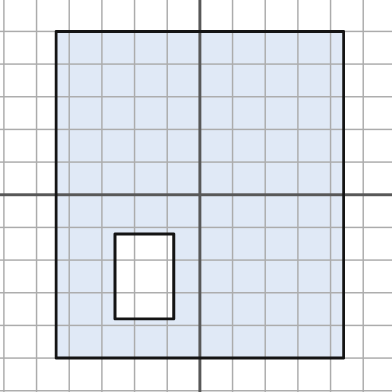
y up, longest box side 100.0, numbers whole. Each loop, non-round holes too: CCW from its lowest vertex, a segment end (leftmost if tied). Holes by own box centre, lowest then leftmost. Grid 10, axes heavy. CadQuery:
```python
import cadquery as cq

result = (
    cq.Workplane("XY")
    .moveTo(-44.0, -50.0)
    .lineTo(44.0, -50.0)
    .lineTo(44.0, 50.0)
    .lineTo(-44.0, 50.0)
    .close()
    .moveTo(-26.0, -38.0)
    .lineTo(-8.0, -38.0)
    .lineTo(-8.0, -12.0)
    .lineTo(-26.0, -12.0)
    .close()
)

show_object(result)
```